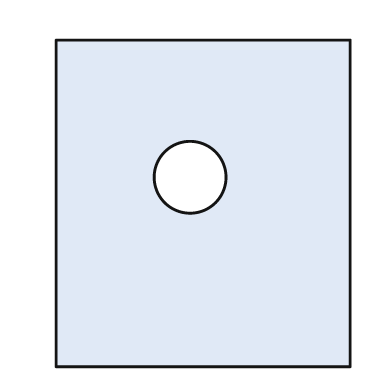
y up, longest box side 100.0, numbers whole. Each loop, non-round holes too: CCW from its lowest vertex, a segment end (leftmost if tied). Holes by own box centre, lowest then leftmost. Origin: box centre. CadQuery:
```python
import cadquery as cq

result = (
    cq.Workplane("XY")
    .moveTo(-45.0, -50.0)
    .lineTo(45.0, -50.0)
    .lineTo(45.0, 50.0)
    .lineTo(-45.0, 50.0)
    .close()
    .moveTo(-4.0, 8.0)
    .circle(11.0)
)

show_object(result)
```